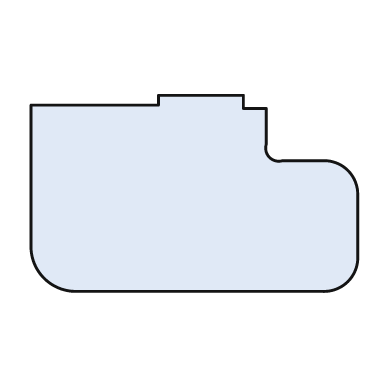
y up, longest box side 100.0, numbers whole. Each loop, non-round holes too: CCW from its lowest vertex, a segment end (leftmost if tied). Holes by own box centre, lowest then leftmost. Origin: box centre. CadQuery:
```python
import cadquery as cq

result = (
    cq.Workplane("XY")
    .moveTo(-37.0, -30.0)
    .lineTo(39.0, -30.0)
    .threePointArc((47.0, -27.0), (50.0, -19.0))
    .lineTo(50.0, 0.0)
    .threePointArc((47.0, 7.0), (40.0, 10.0))
    .lineTo(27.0, 10.0)
    .threePointArc((23.0, 11.0), (22.0, 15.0))
    .lineTo(22.0, 26.0)
    .lineTo(15.0, 26.0)
    .lineTo(15.0, 30.0)
    .lineTo(-11.0, 30.0)
    .lineTo(-11.0, 27.0)
    .lineTo(-50.0, 27.0)
    .lineTo(-50.0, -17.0)
    .threePointArc((-46.0, -26.0), (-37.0, -30.0))
    .close()
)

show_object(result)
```